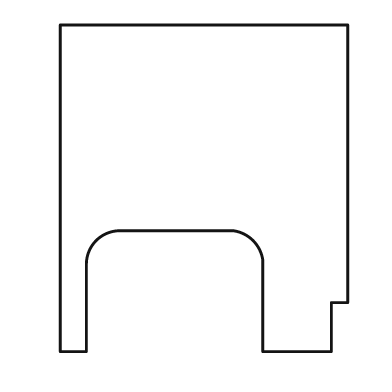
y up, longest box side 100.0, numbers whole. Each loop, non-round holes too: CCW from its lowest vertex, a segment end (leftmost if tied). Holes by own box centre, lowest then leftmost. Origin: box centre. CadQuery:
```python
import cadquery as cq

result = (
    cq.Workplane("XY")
    .moveTo(-44.0, -50.0)
    .lineTo(-36.0, -50.0)
    .lineTo(-36.0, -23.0)
    .threePointArc((-33.0, -16.0), (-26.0, -13.0))
    .lineTo(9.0, -13.0)
    .threePointArc((15.0, -16.0), (18.0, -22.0))
    .lineTo(18.0, -50.0)
    .lineTo(39.0, -50.0)
    .lineTo(39.0, -35.0)
    .lineTo(44.0, -35.0)
    .lineTo(44.0, 50.0)
    .lineTo(-44.0, 50.0)
    .close()
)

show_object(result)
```